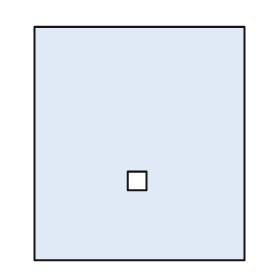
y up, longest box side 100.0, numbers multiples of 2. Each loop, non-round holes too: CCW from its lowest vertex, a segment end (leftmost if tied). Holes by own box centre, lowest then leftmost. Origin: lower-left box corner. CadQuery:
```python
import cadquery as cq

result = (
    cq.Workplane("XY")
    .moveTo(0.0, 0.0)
    .lineTo(90.0, 0.0)
    .lineTo(90.0, 100.0)
    .lineTo(0.0, 100.0)
    .close()
    .moveTo(40.0, 30.0)
    .lineTo(48.0, 30.0)
    .lineTo(48.0, 38.0)
    .lineTo(40.0, 38.0)
    .close()
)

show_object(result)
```